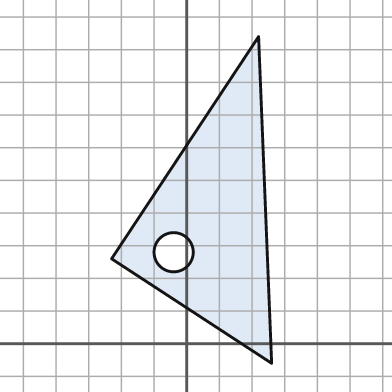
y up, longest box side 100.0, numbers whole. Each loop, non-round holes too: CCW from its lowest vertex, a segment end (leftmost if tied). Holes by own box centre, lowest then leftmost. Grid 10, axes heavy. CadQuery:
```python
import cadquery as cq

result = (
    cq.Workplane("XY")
    .moveTo(26.0, -6.0)
    .lineTo(22.0, 94.0)
    .lineTo(-23.0, 26.0)
    .close()
    .moveTo(-4.0, 28.0)
    .circle(6.0)
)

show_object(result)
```